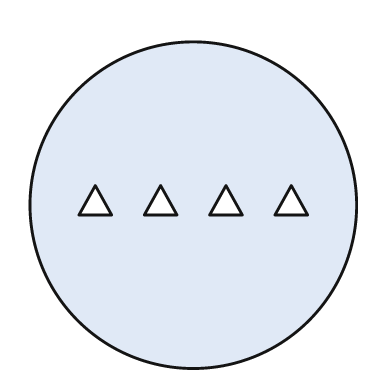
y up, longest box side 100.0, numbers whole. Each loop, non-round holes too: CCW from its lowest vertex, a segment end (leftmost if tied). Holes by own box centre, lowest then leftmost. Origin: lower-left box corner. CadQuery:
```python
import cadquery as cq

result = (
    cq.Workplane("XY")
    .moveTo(50.0, 50.0)
    .circle(50.0)
    .moveTo(15.0, 47.0)
    .lineTo(25.0, 47.0)
    .lineTo(20.0, 56.0)
    .close()
    .moveTo(35.0, 47.0)
    .lineTo(45.0, 47.0)
    .lineTo(40.0, 56.0)
    .close()
    .moveTo(55.0, 47.0)
    .lineTo(65.0, 47.0)
    .lineTo(60.0, 56.0)
    .close()
    .moveTo(75.0, 47.0)
    .lineTo(85.0, 47.0)
    .lineTo(80.0, 56.0)
    .close()
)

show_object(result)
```